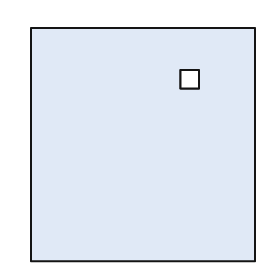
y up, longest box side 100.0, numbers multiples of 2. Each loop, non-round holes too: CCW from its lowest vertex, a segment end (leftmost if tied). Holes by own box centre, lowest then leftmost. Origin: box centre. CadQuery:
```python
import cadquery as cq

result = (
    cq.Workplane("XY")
    .moveTo(-48.0, -50.0)
    .lineTo(48.0, -50.0)
    .lineTo(48.0, 50.0)
    .lineTo(-48.0, 50.0)
    .close()
    .moveTo(16.0, 24.0)
    .lineTo(24.0, 24.0)
    .lineTo(24.0, 32.0)
    .lineTo(16.0, 32.0)
    .close()
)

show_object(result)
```